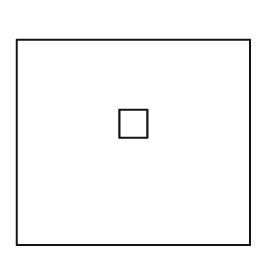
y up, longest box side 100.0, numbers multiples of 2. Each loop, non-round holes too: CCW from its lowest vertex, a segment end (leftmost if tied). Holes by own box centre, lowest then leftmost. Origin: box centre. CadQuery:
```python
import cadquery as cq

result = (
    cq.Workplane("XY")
    .moveTo(-50.0, -44.0)
    .lineTo(50.0, -44.0)
    .lineTo(50.0, 44.0)
    .lineTo(-50.0, 44.0)
    .close()
    .moveTo(-6.0, 2.0)
    .lineTo(6.0, 2.0)
    .lineTo(6.0, 14.0)
    .lineTo(-6.0, 14.0)
    .close()
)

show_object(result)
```